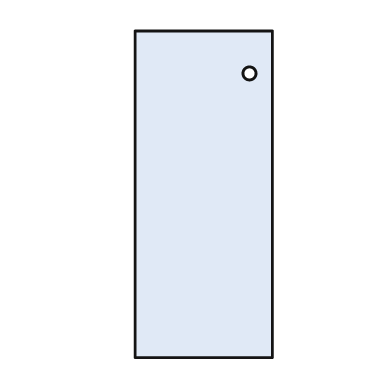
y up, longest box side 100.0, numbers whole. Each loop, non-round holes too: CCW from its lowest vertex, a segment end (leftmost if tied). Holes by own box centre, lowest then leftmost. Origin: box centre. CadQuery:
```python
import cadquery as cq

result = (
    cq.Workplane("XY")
    .moveTo(-21.0, -50.0)
    .lineTo(21.0, -50.0)
    .lineTo(21.0, 50.0)
    .lineTo(-21.0, 50.0)
    .close()
    .moveTo(14.0, 37.0)
    .circle(2.0)
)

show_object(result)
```